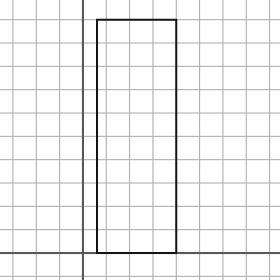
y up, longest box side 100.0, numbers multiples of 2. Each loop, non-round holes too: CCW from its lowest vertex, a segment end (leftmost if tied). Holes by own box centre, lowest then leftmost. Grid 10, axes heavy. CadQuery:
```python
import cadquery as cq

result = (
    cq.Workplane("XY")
    .moveTo(6.0, 0.0)
    .lineTo(40.0, 0.0)
    .lineTo(40.0, 100.0)
    .lineTo(6.0, 100.0)
    .close()
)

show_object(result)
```